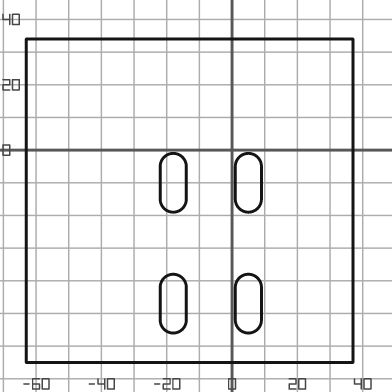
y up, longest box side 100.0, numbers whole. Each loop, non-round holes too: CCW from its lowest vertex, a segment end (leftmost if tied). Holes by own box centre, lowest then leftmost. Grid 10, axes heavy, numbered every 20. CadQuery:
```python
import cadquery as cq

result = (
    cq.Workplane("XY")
    .moveTo(-63.0, -65.0)
    .lineTo(37.0, -65.0)
    .lineTo(37.0, 34.0)
    .lineTo(-63.0, 34.0)
    .close()
    .moveTo(-22.0, -52.0)
    .threePointArc((-18.0, -56.0), (-14.0, -52.0))
    .lineTo(-14.0, -42.0)
    .threePointArc((-18.0, -38.0), (-22.0, -42.0))
    .close()
    .moveTo(1.0, -52.0)
    .threePointArc((5.0, -56.0), (9.0, -52.0))
    .lineTo(9.0, -42.0)
    .threePointArc((5.0, -38.0), (1.0, -42.0))
    .close()
    .moveTo(-22.0, -15.0)
    .threePointArc((-18.0, -19.0), (-14.0, -15.0))
    .lineTo(-14.0, -5.0)
    .threePointArc((-18.0, -1.0), (-22.0, -5.0))
    .close()
    .moveTo(1.0, -15.0)
    .threePointArc((5.0, -19.0), (9.0, -15.0))
    .lineTo(9.0, -5.0)
    .threePointArc((5.0, -1.0), (1.0, -5.0))
    .close()
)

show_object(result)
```